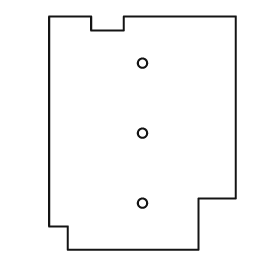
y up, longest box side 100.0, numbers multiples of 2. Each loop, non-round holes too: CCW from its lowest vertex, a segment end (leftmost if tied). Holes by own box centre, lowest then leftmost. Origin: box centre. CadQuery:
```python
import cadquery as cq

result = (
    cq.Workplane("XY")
    .moveTo(-32.0, -50.0)
    .lineTo(24.0, -50.0)
    .lineTo(24.0, -28.0)
    .lineTo(40.0, -28.0)
    .lineTo(40.0, 50.0)
    .lineTo(-8.0, 50.0)
    .lineTo(-8.0, 44.0)
    .lineTo(-22.0, 44.0)
    .lineTo(-22.0, 50.0)
    .lineTo(-40.0, 50.0)
    .lineTo(-40.0, -40.0)
    .lineTo(-32.0, -40.0)
    .close()
    .moveTo(0.0, -30.0)
    .circle(2.0)
    .moveTo(0.0, 0.0)
    .circle(2.0)
    .moveTo(0.0, 30.0)
    .circle(2.0)
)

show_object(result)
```